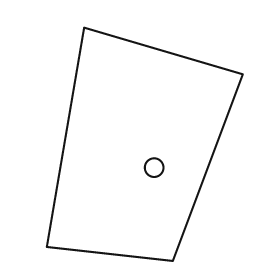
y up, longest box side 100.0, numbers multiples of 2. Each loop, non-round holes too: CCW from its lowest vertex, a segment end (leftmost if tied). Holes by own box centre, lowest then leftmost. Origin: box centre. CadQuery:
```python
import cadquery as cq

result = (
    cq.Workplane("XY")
    .moveTo(12.0, -50.0)
    .lineTo(42.0, 30.0)
    .lineTo(-26.0, 50.0)
    .lineTo(-42.0, -44.0)
    .close()
    .moveTo(4.0, -10.0)
    .circle(4.0)
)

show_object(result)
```